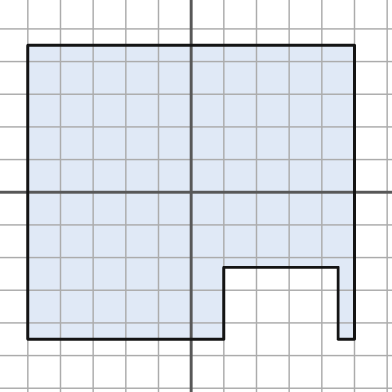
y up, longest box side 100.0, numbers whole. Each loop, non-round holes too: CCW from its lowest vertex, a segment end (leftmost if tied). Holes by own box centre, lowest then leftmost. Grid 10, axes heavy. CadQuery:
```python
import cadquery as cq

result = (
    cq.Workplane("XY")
    .moveTo(-50.0, -45.0)
    .lineTo(10.0, -45.0)
    .lineTo(10.0, -23.0)
    .lineTo(45.0, -23.0)
    .lineTo(45.0, -45.0)
    .lineTo(50.0, -45.0)
    .lineTo(50.0, 45.0)
    .lineTo(-50.0, 45.0)
    .close()
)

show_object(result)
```